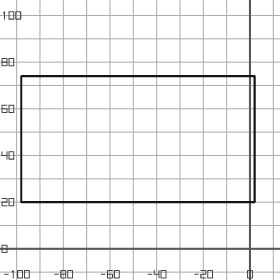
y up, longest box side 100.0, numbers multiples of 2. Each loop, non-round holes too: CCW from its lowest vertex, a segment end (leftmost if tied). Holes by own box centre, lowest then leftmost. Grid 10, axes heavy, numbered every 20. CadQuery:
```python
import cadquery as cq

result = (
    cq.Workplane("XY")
    .moveTo(-98.0, 20.0)
    .lineTo(2.0, 20.0)
    .lineTo(2.0, 74.0)
    .lineTo(-98.0, 74.0)
    .close()
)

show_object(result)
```